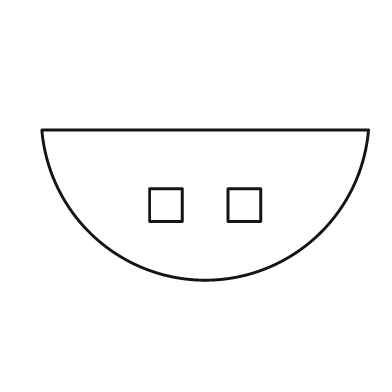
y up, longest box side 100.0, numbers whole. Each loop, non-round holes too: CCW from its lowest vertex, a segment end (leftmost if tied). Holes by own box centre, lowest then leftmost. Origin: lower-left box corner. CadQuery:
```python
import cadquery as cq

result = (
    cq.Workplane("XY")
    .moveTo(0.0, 46.0)
    .threePointArc((50.0, 0.0), (100.0, 46.0))
    .close()
    .moveTo(33.0, 18.0)
    .lineTo(43.0, 18.0)
    .lineTo(43.0, 28.0)
    .lineTo(33.0, 28.0)
    .close()
    .moveTo(57.0, 18.0)
    .lineTo(67.0, 18.0)
    .lineTo(67.0, 28.0)
    .lineTo(57.0, 28.0)
    .close()
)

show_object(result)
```